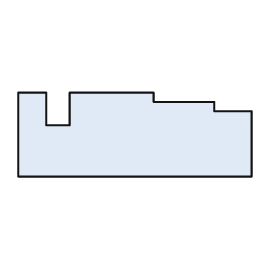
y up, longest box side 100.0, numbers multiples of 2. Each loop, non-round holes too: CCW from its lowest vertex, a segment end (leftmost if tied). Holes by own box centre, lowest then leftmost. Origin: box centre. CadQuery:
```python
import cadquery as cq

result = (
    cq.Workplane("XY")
    .moveTo(-50.0, -18.0)
    .lineTo(50.0, -18.0)
    .lineTo(50.0, 10.0)
    .lineTo(34.0, 10.0)
    .lineTo(34.0, 14.0)
    .lineTo(8.0, 14.0)
    .lineTo(8.0, 18.0)
    .lineTo(-28.0, 18.0)
    .lineTo(-28.0, 4.0)
    .lineTo(-38.0, 4.0)
    .lineTo(-38.0, 18.0)
    .lineTo(-50.0, 18.0)
    .close()
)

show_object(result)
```